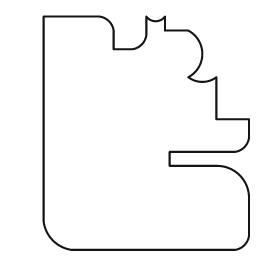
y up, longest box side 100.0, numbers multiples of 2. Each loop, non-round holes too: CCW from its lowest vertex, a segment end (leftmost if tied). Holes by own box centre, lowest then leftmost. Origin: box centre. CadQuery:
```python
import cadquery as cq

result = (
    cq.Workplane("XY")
    .moveTo(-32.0, -50.0)
    .lineTo(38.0, -50.0)
    .threePointArc((42.0, -48.0), (44.0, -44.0))
    .lineTo(44.0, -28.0)
    .threePointArc((40.0, -18.0), (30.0, -14.0))
    .lineTo(10.0, -14.0)
    .lineTo(10.0, -8.0)
    .lineTo(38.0, -8.0)
    .threePointArc((42.0, -6.0), (44.0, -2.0))
    .lineTo(44.0, 6.0)
    .lineTo(30.0, 6.0)
    .lineTo(30.0, 24.0)
    .threePointArc((24.0, 22.0), (18.0, 24.0))
    .threePointArc((24.0, 34.0), (18.0, 44.0))
    .lineTo(8.0, 44.0)
    .lineTo(8.0, 50.0)
    .threePointArc((4.0, 48.0), (0.0, 50.0))
    .lineTo(0.0, 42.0)
    .threePointArc((-2.0, 38.0), (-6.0, 36.0))
    .lineTo(-14.0, 36.0)
    .lineTo(-14.0, 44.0)
    .threePointArc((-16.0, 48.0), (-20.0, 50.0))
    .lineTo(-44.0, 50.0)
    .lineTo(-44.0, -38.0)
    .threePointArc((-40.0, -46.0), (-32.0, -50.0))
    .close()
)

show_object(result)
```